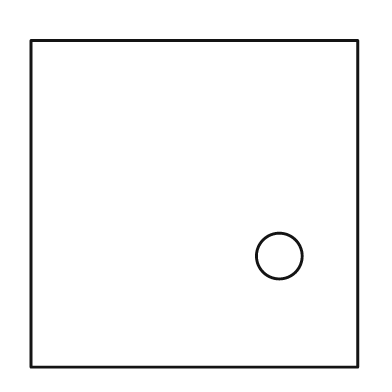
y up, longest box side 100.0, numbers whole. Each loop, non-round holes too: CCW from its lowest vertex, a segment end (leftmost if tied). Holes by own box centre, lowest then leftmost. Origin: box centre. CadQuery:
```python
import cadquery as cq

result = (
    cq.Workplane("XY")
    .moveTo(-50.0, -50.0)
    .lineTo(50.0, -50.0)
    .lineTo(50.0, 50.0)
    .lineTo(-50.0, 50.0)
    .close()
    .moveTo(26.0, -16.0)
    .circle(7.0)
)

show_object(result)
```